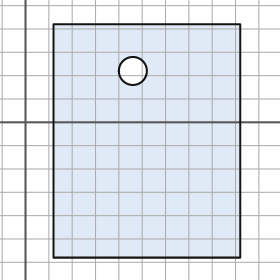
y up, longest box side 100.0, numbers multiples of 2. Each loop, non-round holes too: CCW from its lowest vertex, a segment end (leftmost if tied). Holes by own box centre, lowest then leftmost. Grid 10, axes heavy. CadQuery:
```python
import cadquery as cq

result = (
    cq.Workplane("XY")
    .moveTo(12.0, -58.0)
    .lineTo(92.0, -58.0)
    .lineTo(92.0, 42.0)
    .lineTo(12.0, 42.0)
    .close()
    .moveTo(46.0, 22.0)
    .circle(6.0)
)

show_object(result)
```